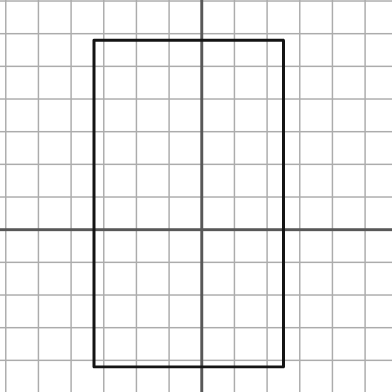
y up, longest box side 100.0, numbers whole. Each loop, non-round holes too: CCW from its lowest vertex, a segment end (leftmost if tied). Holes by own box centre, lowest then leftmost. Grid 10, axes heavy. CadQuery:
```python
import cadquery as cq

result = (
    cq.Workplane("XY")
    .moveTo(-33.0, -42.0)
    .lineTo(25.0, -42.0)
    .lineTo(25.0, 58.0)
    .lineTo(-33.0, 58.0)
    .close()
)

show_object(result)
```